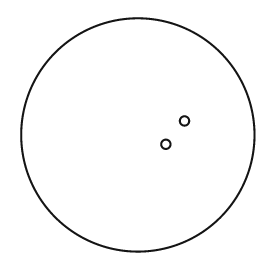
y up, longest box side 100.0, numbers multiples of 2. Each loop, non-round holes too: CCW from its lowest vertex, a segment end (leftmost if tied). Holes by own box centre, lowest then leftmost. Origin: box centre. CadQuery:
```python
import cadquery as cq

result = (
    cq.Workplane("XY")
    .moveTo(0.0, 0.0)
    .circle(50.0)
    .moveTo(12.0, -4.0)
    .circle(2.0)
    .moveTo(20.0, 6.0)
    .circle(2.0)
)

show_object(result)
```